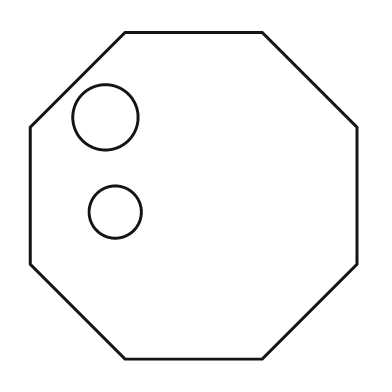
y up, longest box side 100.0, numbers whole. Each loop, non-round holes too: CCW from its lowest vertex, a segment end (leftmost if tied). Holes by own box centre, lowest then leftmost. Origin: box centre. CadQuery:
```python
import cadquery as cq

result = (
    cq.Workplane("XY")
    .moveTo(-21.0, -50.0)
    .lineTo(21.0, -50.0)
    .lineTo(50.0, -21.0)
    .lineTo(50.0, 21.0)
    .lineTo(21.0, 50.0)
    .lineTo(-21.0, 50.0)
    .lineTo(-50.0, 21.0)
    .lineTo(-50.0, -21.0)
    .close()
    .moveTo(-24.0, -5.0)
    .circle(8.0)
    .moveTo(-27.0, 24.0)
    .circle(10.0)
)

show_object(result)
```